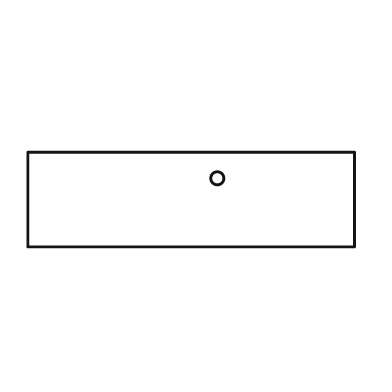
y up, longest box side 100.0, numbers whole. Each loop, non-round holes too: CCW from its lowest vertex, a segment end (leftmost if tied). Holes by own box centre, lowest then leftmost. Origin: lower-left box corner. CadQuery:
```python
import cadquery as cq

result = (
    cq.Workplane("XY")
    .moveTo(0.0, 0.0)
    .lineTo(100.0, 0.0)
    .lineTo(100.0, 29.0)
    .lineTo(0.0, 29.0)
    .close()
    .moveTo(58.0, 21.0)
    .circle(2.0)
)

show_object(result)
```